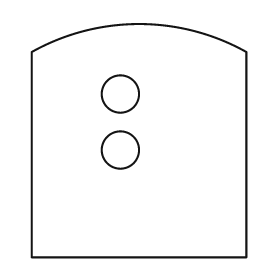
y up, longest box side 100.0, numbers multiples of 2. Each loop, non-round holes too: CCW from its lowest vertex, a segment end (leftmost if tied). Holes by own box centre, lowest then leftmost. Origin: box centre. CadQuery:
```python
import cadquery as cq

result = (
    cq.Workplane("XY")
    .moveTo(-46.0, -50.0)
    .lineTo(46.0, -50.0)
    .lineTo(46.0, 38.0)
    .threePointArc((0.0, 50.0), (-46.0, 38.0))
    .close()
    .moveTo(-8.0, -4.0)
    .circle(8.0)
    .moveTo(-8.0, 20.0)
    .circle(8.0)
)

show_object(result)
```